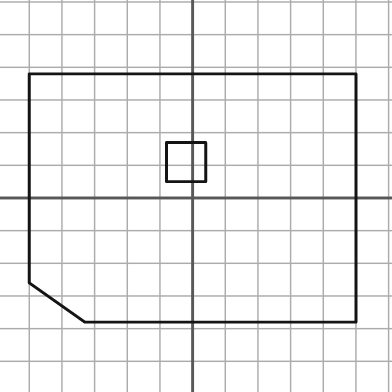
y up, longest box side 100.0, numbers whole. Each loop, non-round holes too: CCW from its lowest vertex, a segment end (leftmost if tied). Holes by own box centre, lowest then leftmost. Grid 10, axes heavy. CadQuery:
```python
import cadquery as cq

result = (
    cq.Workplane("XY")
    .moveTo(-33.0, -38.0)
    .lineTo(50.0, -38.0)
    .lineTo(50.0, 38.0)
    .lineTo(-50.0, 38.0)
    .lineTo(-50.0, -26.0)
    .close()
    .moveTo(-8.0, 5.0)
    .lineTo(4.0, 5.0)
    .lineTo(4.0, 17.0)
    .lineTo(-8.0, 17.0)
    .close()
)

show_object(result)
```